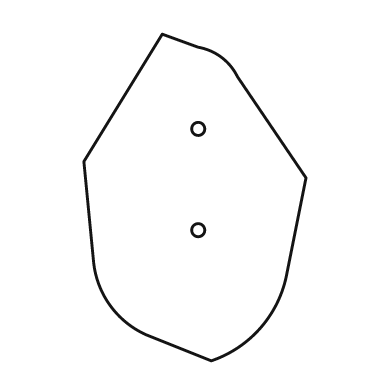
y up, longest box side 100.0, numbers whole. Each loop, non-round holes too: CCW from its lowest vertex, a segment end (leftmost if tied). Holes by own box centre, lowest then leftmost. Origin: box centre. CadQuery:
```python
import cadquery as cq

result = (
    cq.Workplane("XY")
    .moveTo(5.0, -50.0)
    .threePointArc((20.0, -40.0), (28.0, -24.0))
    .lineTo(34.0, 6.0)
    .lineTo(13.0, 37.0)
    .threePointArc((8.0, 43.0), (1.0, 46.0))
    .lineTo(-10.0, 50.0)
    .lineTo(-34.0, 11.0)
    .lineTo(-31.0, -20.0)
    .threePointArc((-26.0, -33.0), (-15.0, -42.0))
    .close()
    .moveTo(1.0, -10.0)
    .circle(2.0)
    .moveTo(1.0, 21.0)
    .circle(2.0)
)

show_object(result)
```